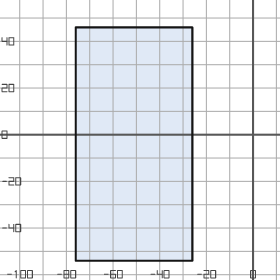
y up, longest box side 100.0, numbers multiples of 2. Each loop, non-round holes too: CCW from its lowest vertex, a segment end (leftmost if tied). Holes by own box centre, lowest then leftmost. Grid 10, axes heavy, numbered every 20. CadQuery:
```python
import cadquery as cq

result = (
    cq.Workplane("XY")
    .moveTo(-76.0, -54.0)
    .lineTo(-26.0, -54.0)
    .lineTo(-26.0, 46.0)
    .lineTo(-76.0, 46.0)
    .close()
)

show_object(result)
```